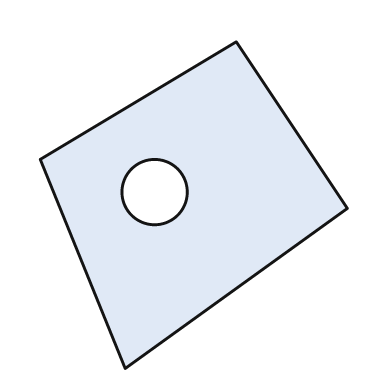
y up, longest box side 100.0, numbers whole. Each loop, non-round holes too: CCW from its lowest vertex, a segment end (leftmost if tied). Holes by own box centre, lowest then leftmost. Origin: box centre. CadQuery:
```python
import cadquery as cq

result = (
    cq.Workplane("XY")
    .moveTo(-21.0, -50.0)
    .lineTo(47.0, -1.0)
    .lineTo(13.0, 50.0)
    .lineTo(-47.0, 14.0)
    .close()
    .moveTo(-12.0, 4.0)
    .circle(10.0)
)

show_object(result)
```